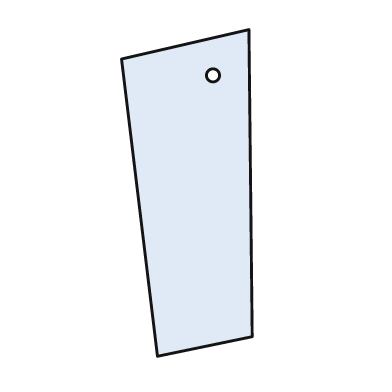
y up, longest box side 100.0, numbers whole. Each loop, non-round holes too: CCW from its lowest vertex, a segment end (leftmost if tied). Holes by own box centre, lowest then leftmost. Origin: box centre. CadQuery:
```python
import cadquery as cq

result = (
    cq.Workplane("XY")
    .moveTo(-9.0, -50.0)
    .lineTo(20.0, -44.0)
    .lineTo(19.0, 50.0)
    .lineTo(-20.0, 41.0)
    .close()
    .moveTo(8.0, 36.0)
    .circle(2.0)
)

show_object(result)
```